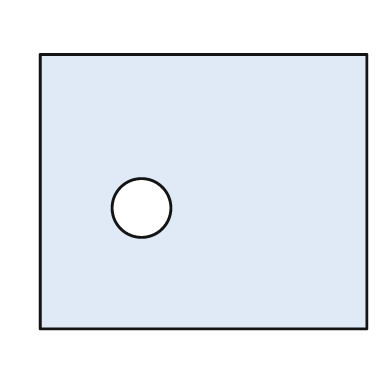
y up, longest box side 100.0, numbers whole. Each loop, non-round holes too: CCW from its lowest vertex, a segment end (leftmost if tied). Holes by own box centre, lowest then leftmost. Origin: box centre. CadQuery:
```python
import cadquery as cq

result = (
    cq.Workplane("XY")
    .moveTo(-50.0, -42.0)
    .lineTo(50.0, -42.0)
    .lineTo(50.0, 42.0)
    .lineTo(-50.0, 42.0)
    .close()
    .moveTo(-19.0, -5.0)
    .circle(9.0)
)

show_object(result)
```